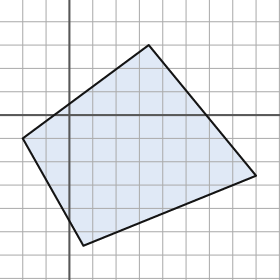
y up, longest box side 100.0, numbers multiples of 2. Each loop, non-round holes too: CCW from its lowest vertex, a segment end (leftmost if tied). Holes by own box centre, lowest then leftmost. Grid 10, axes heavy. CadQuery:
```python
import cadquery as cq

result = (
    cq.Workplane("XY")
    .moveTo(6.0, -56.0)
    .lineTo(80.0, -26.0)
    .lineTo(34.0, 30.0)
    .lineTo(-20.0, -10.0)
    .close()
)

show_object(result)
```